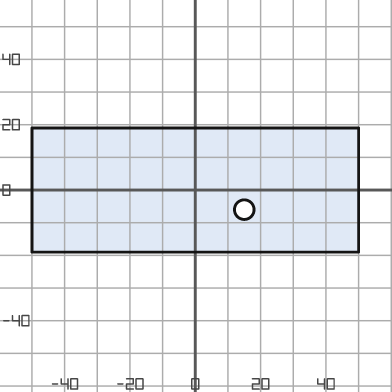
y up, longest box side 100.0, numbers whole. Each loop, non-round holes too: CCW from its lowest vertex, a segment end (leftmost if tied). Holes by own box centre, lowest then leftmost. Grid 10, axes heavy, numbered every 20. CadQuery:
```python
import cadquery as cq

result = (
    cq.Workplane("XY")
    .moveTo(-50.0, -19.0)
    .lineTo(50.0, -19.0)
    .lineTo(50.0, 19.0)
    .lineTo(-50.0, 19.0)
    .close()
    .moveTo(15.0, -6.0)
    .circle(3.0)
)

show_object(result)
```